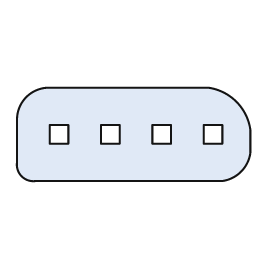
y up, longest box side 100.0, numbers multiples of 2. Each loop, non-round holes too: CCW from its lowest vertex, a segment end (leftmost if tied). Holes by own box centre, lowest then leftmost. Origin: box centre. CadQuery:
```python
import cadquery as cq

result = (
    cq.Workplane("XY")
    .moveTo(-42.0, -20.0)
    .lineTo(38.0, -20.0)
    .threePointArc((46.0, -16.0), (50.0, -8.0))
    .lineTo(50.0, 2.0)
    .threePointArc((44.0, 14.0), (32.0, 20.0))
    .lineTo(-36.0, 20.0)
    .threePointArc((-46.0, 16.0), (-50.0, 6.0))
    .lineTo(-50.0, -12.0)
    .threePointArc((-48.0, -18.0), (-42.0, -20.0))
    .close()
    .moveTo(-36.0, -4.0)
    .lineTo(-28.0, -4.0)
    .lineTo(-28.0, 4.0)
    .lineTo(-36.0, 4.0)
    .close()
    .moveTo(-14.0, -4.0)
    .lineTo(-6.0, -4.0)
    .lineTo(-6.0, 4.0)
    .lineTo(-14.0, 4.0)
    .close()
    .moveTo(8.0, -4.0)
    .lineTo(16.0, -4.0)
    .lineTo(16.0, 4.0)
    .lineTo(8.0, 4.0)
    .close()
    .moveTo(30.0, -4.0)
    .lineTo(38.0, -4.0)
    .lineTo(38.0, 4.0)
    .lineTo(30.0, 4.0)
    .close()
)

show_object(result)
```